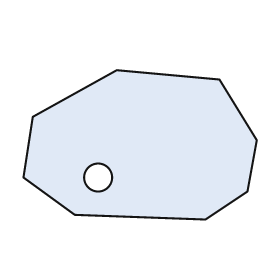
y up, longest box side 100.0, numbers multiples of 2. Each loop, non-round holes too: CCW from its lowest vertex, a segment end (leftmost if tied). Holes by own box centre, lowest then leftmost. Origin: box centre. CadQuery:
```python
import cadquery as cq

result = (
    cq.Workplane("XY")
    .moveTo(28.0, -32.0)
    .lineTo(46.0, -20.0)
    .lineTo(50.0, 2.0)
    .lineTo(34.0, 28.0)
    .lineTo(-10.0, 32.0)
    .lineTo(-46.0, 12.0)
    .lineTo(-50.0, -14.0)
    .lineTo(-28.0, -30.0)
    .close()
    .moveTo(-18.0, -14.0)
    .circle(6.0)
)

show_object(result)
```